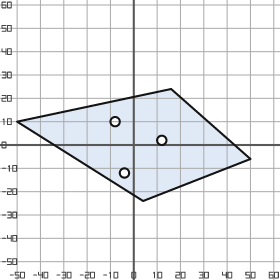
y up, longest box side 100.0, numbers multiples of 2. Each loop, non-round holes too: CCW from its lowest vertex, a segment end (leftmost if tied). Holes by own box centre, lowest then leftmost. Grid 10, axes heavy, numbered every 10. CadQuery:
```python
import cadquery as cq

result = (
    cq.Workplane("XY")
    .moveTo(4.0, -24.0)
    .lineTo(50.0, -6.0)
    .lineTo(16.0, 24.0)
    .lineTo(-50.0, 10.0)
    .close()
    .moveTo(-4.0, -12.0)
    .circle(2.0)
    .moveTo(12.0, 2.0)
    .circle(2.0)
    .moveTo(-8.0, 10.0)
    .circle(2.0)
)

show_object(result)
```